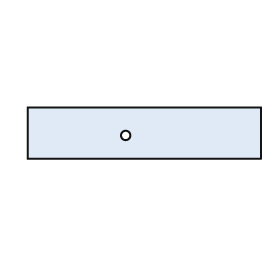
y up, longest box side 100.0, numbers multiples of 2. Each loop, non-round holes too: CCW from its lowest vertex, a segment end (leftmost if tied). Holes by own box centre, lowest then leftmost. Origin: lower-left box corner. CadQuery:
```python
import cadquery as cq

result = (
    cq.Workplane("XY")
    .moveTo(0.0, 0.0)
    .lineTo(100.0, 0.0)
    .lineTo(100.0, 22.0)
    .lineTo(0.0, 22.0)
    .close()
    .moveTo(42.0, 10.0)
    .circle(2.0)
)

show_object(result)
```